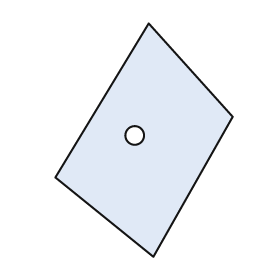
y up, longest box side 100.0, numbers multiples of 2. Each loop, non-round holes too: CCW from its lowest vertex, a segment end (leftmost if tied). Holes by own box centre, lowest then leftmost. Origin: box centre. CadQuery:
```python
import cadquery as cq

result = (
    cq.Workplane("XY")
    .moveTo(4.0, -50.0)
    .lineTo(38.0, 10.0)
    .lineTo(2.0, 50.0)
    .lineTo(-38.0, -16.0)
    .close()
    .moveTo(-4.0, 2.0)
    .circle(4.0)
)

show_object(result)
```